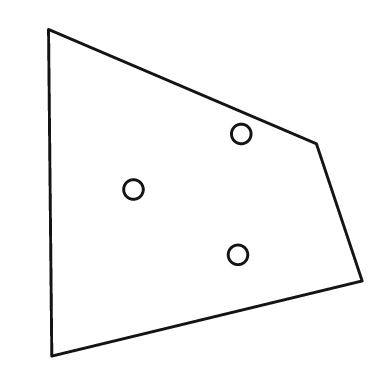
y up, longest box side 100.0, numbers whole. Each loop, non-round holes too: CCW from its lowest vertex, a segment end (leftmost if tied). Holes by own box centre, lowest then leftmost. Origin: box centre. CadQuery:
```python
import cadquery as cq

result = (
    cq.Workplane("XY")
    .moveTo(-47.0, -50.0)
    .lineTo(48.0, -27.0)
    .lineTo(34.0, 15.0)
    .lineTo(-48.0, 50.0)
    .close()
    .moveTo(10.0, -19.0)
    .circle(3.0)
    .moveTo(-22.0, 1.0)
    .circle(3.0)
    .moveTo(11.0, 18.0)
    .circle(3.0)
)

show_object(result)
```